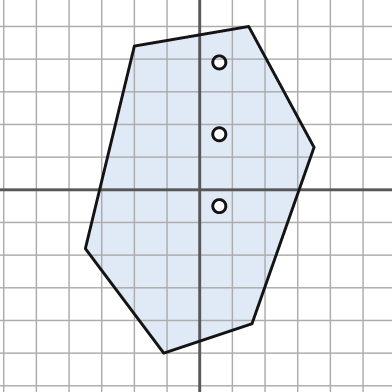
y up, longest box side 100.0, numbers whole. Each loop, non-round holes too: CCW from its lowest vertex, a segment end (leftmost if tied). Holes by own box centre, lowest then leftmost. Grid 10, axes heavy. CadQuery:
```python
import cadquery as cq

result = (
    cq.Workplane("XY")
    .moveTo(-11.0, -50.0)
    .lineTo(16.0, -41.0)
    .lineTo(35.0, 13.0)
    .lineTo(15.0, 50.0)
    .lineTo(-20.0, 44.0)
    .lineTo(-35.0, -18.0)
    .close()
    .moveTo(6.0, -5.0)
    .circle(2.0)
    .moveTo(6.0, 17.0)
    .circle(2.0)
    .moveTo(6.0, 39.0)
    .circle(2.0)
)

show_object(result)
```